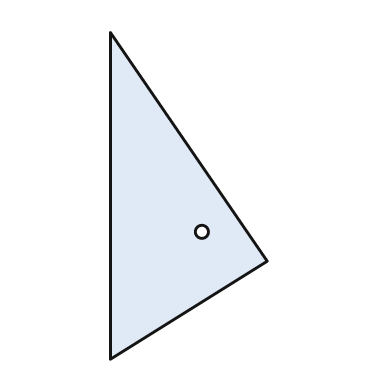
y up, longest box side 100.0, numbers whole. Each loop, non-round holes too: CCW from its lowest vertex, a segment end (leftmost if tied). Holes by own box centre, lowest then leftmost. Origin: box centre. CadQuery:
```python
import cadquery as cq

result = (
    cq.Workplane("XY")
    .moveTo(-24.0, -50.0)
    .lineTo(24.0, -20.0)
    .lineTo(-24.0, 50.0)
    .close()
    .moveTo(4.0, -11.0)
    .circle(2.0)
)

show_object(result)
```